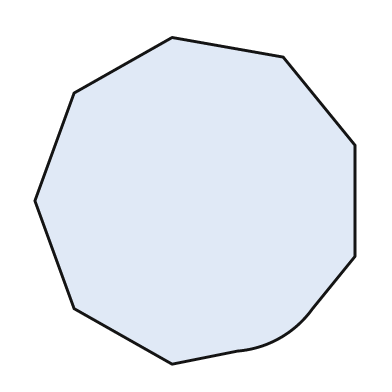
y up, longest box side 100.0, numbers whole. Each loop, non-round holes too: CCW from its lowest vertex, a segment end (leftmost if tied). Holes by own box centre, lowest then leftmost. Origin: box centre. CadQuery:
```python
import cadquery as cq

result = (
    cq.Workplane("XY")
    .moveTo(-7.0, -50.0)
    .lineTo(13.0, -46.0)
    .threePointArc((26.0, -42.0), (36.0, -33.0))
    .lineTo(49.0, -17.0)
    .lineTo(49.0, 17.0)
    .lineTo(27.0, 44.0)
    .lineTo(-7.0, 50.0)
    .lineTo(-37.0, 33.0)
    .lineTo(-49.0, 0.0)
    .lineTo(-37.0, -33.0)
    .close()
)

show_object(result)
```